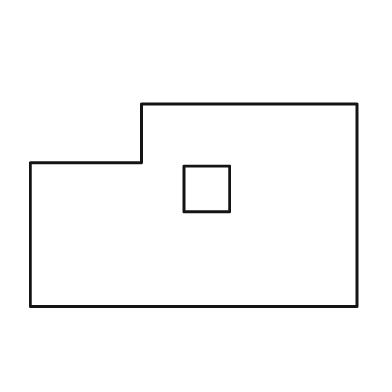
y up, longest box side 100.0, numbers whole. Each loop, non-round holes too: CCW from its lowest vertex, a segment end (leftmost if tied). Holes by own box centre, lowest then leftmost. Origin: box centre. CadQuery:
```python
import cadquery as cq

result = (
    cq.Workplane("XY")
    .moveTo(-50.0, -31.0)
    .lineTo(50.0, -31.0)
    .lineTo(50.0, 31.0)
    .lineTo(-16.0, 31.0)
    .lineTo(-16.0, 13.0)
    .lineTo(-50.0, 13.0)
    .close()
    .moveTo(-3.0, -2.0)
    .lineTo(11.0, -2.0)
    .lineTo(11.0, 12.0)
    .lineTo(-3.0, 12.0)
    .close()
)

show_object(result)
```